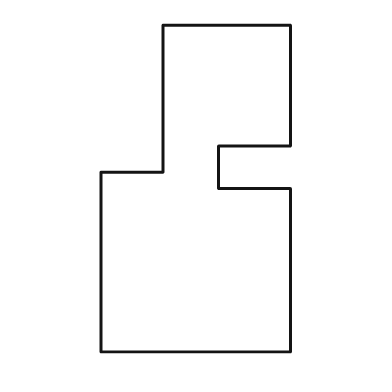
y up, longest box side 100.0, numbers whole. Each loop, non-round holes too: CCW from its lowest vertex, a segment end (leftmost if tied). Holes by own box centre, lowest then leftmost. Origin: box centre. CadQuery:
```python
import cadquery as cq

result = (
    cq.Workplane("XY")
    .moveTo(-29.0, -50.0)
    .lineTo(29.0, -50.0)
    .lineTo(29.0, 0.0)
    .lineTo(7.0, 0.0)
    .lineTo(7.0, 13.0)
    .lineTo(29.0, 13.0)
    .lineTo(29.0, 50.0)
    .lineTo(-10.0, 50.0)
    .lineTo(-10.0, 5.0)
    .lineTo(-29.0, 5.0)
    .close()
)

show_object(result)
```